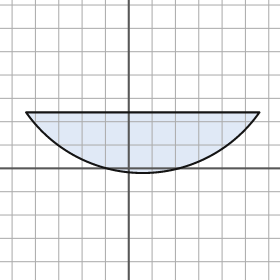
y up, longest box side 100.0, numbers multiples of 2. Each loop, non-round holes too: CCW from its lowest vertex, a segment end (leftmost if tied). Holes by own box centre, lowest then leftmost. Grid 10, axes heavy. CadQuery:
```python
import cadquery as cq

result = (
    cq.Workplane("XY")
    .moveTo(-44.0, 24.0)
    .threePointArc((6.0, -2.0), (56.0, 24.0))
    .close()
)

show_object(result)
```